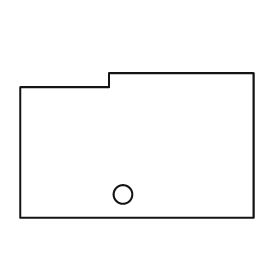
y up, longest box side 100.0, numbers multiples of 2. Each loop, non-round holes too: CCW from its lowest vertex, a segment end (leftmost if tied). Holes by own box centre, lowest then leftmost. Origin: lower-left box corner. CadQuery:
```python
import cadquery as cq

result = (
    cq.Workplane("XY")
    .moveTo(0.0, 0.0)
    .lineTo(100.0, 0.0)
    .lineTo(100.0, 62.0)
    .lineTo(38.0, 62.0)
    .lineTo(38.0, 56.0)
    .lineTo(0.0, 56.0)
    .close()
    .moveTo(44.0, 10.0)
    .circle(4.0)
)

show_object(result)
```